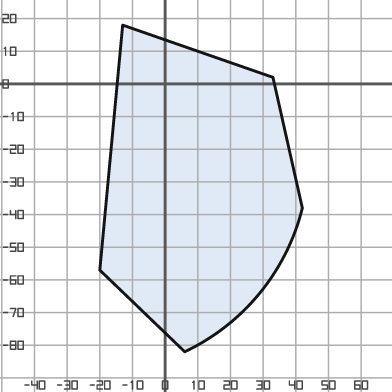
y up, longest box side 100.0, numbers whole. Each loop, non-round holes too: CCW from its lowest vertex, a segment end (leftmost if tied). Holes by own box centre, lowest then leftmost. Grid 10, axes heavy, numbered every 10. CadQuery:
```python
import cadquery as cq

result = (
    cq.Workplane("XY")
    .moveTo(6.0, -82.0)
    .threePointArc((29.0, -64.0), (42.0, -38.0))
    .lineTo(33.0, 2.0)
    .lineTo(-13.0, 18.0)
    .lineTo(-20.0, -57.0)
    .close()
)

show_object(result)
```